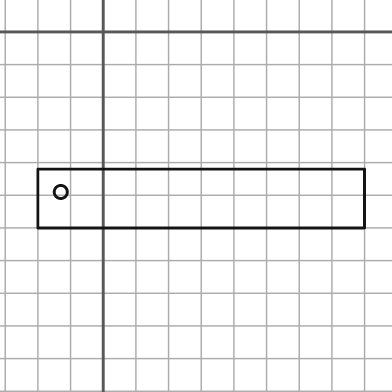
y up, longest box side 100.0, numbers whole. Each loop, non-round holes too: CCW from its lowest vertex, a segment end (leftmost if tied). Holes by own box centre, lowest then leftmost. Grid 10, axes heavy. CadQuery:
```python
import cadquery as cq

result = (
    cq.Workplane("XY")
    .moveTo(-20.0, -60.0)
    .lineTo(80.0, -60.0)
    .lineTo(80.0, -42.0)
    .lineTo(-20.0, -42.0)
    .close()
    .moveTo(-13.0, -49.0)
    .circle(2.0)
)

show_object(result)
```